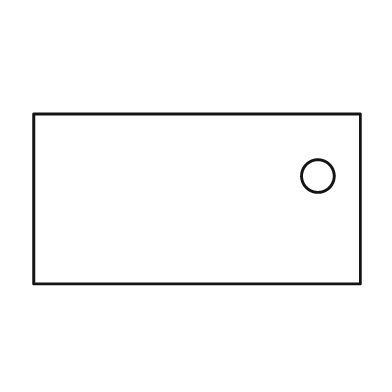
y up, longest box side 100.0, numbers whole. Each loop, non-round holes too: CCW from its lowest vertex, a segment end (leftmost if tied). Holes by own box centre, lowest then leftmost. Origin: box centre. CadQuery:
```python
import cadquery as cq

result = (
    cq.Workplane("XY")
    .moveTo(-50.0, -26.0)
    .lineTo(50.0, -26.0)
    .lineTo(50.0, 26.0)
    .lineTo(-50.0, 26.0)
    .close()
    .moveTo(37.0, 7.0)
    .circle(5.0)
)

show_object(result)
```